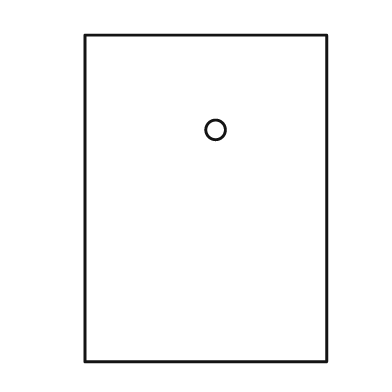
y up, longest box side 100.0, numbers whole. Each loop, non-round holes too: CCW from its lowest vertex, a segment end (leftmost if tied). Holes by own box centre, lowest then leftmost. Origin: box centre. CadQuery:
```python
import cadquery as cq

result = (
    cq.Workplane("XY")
    .moveTo(-37.0, -50.0)
    .lineTo(37.0, -50.0)
    .lineTo(37.0, 50.0)
    .lineTo(-37.0, 50.0)
    .close()
    .moveTo(3.0, 21.0)
    .circle(3.0)
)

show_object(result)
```